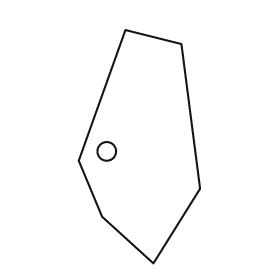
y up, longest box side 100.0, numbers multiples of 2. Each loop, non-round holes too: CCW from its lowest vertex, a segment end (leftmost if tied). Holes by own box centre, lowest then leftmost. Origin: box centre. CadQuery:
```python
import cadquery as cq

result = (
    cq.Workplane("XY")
    .moveTo(6.0, -50.0)
    .lineTo(26.0, -18.0)
    .lineTo(18.0, 44.0)
    .lineTo(-6.0, 50.0)
    .lineTo(-26.0, -6.0)
    .lineTo(-16.0, -30.0)
    .close()
    .moveTo(-14.0, -2.0)
    .circle(4.0)
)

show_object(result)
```